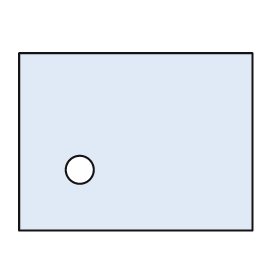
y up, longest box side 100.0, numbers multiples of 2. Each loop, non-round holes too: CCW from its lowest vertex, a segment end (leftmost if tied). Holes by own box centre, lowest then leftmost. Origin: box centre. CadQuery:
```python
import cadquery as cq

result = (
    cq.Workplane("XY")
    .moveTo(-50.0, -38.0)
    .lineTo(50.0, -38.0)
    .lineTo(50.0, 38.0)
    .lineTo(-50.0, 38.0)
    .close()
    .moveTo(-24.0, -12.0)
    .circle(6.0)
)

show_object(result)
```